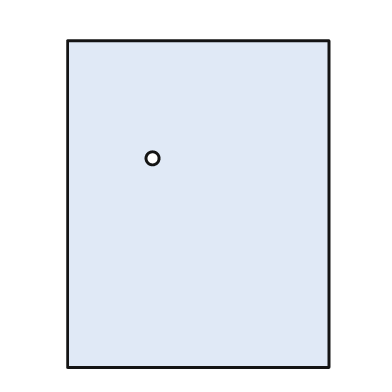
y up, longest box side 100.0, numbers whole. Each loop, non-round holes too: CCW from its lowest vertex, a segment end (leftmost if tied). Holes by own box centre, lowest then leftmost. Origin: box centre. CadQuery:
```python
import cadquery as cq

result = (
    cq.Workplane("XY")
    .moveTo(-40.0, -50.0)
    .lineTo(40.0, -50.0)
    .lineTo(40.0, 50.0)
    .lineTo(-40.0, 50.0)
    .close()
    .moveTo(-14.0, 14.0)
    .circle(2.0)
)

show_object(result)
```